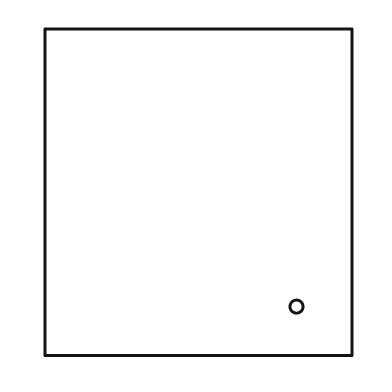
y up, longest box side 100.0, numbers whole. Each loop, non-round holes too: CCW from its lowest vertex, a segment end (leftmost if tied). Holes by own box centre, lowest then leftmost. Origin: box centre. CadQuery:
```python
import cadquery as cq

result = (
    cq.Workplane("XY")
    .moveTo(-47.0, -50.0)
    .lineTo(47.0, -50.0)
    .lineTo(47.0, 50.0)
    .lineTo(-47.0, 50.0)
    .close()
    .moveTo(30.0, -35.0)
    .circle(2.0)
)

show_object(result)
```